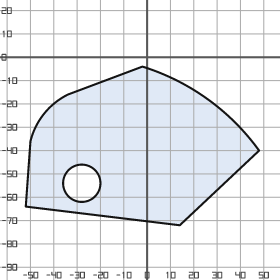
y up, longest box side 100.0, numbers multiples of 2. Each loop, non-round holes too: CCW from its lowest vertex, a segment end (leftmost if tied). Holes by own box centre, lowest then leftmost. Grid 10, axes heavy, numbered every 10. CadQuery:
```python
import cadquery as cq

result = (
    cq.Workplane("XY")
    .moveTo(14.0, -72.0)
    .lineTo(48.0, -40.0)
    .threePointArc((26.0, -18.0), (-2.0, -4.0))
    .lineTo(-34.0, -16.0)
    .threePointArc((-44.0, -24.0), (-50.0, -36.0))
    .lineTo(-52.0, -64.0)
    .close()
    .moveTo(-28.0, -54.0)
    .circle(8.0)
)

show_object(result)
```